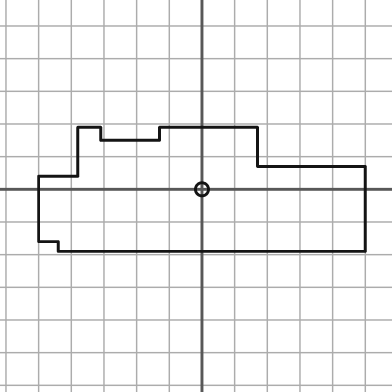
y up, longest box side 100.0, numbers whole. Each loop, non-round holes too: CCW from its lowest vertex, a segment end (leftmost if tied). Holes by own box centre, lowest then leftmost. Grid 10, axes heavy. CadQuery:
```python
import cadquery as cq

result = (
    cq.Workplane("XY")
    .moveTo(-44.0, -19.0)
    .lineTo(50.0, -19.0)
    .lineTo(50.0, 7.0)
    .lineTo(17.0, 7.0)
    .lineTo(17.0, 19.0)
    .lineTo(-13.0, 19.0)
    .lineTo(-13.0, 15.0)
    .lineTo(-31.0, 15.0)
    .lineTo(-31.0, 19.0)
    .lineTo(-38.0, 19.0)
    .lineTo(-38.0, 4.0)
    .lineTo(-50.0, 4.0)
    .lineTo(-50.0, -16.0)
    .lineTo(-44.0, -16.0)
    .close()
    .moveTo(0.0, 0.0)
    .circle(2.0)
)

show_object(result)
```